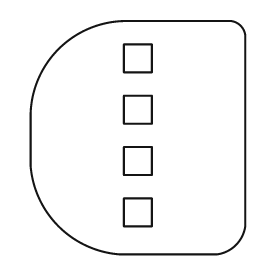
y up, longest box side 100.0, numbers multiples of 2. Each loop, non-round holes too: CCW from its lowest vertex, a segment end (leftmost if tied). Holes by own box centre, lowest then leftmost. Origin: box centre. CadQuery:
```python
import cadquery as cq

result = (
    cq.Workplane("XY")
    .moveTo(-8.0, -50.0)
    .lineTo(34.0, -50.0)
    .threePointArc((42.0, -46.0), (46.0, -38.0))
    .lineTo(46.0, 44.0)
    .threePointArc((44.0, 48.0), (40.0, 50.0))
    .lineTo(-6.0, 50.0)
    .threePointArc((-34.0, 38.0), (-46.0, 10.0))
    .lineTo(-46.0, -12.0)
    .threePointArc((-34.0, -38.0), (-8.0, -50.0))
    .close()
    .moveTo(-6.0, -38.0)
    .lineTo(6.0, -38.0)
    .lineTo(6.0, -26.0)
    .lineTo(-6.0, -26.0)
    .close()
    .moveTo(-6.0, -16.0)
    .lineTo(6.0, -16.0)
    .lineTo(6.0, -4.0)
    .lineTo(-6.0, -4.0)
    .close()
    .moveTo(-6.0, 6.0)
    .lineTo(6.0, 6.0)
    .lineTo(6.0, 18.0)
    .lineTo(-6.0, 18.0)
    .close()
    .moveTo(-6.0, 28.0)
    .lineTo(6.0, 28.0)
    .lineTo(6.0, 40.0)
    .lineTo(-6.0, 40.0)
    .close()
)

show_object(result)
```